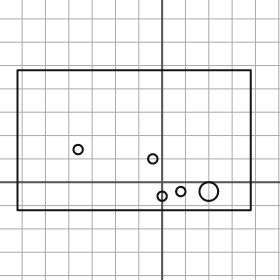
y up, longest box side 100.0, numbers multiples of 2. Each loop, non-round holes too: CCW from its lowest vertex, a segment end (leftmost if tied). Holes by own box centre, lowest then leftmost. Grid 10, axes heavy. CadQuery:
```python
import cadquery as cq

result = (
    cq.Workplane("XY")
    .moveTo(-62.0, -12.0)
    .lineTo(38.0, -12.0)
    .lineTo(38.0, 48.0)
    .lineTo(-62.0, 48.0)
    .close()
    .moveTo(0.0, -6.0)
    .circle(2.0)
    .moveTo(8.0, -4.0)
    .circle(2.0)
    .moveTo(20.0, -4.0)
    .circle(4.0)
    .moveTo(-4.0, 10.0)
    .circle(2.0)
    .moveTo(-36.0, 14.0)
    .circle(2.0)
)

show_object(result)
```